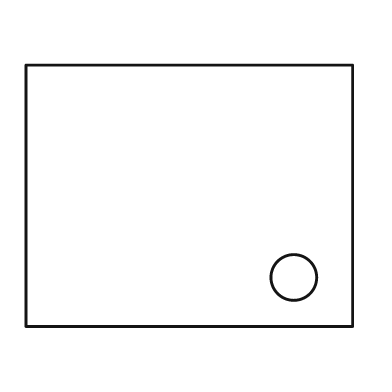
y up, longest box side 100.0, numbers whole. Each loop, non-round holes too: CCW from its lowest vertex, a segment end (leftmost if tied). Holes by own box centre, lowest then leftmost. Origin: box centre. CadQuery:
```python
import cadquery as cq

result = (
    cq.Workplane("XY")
    .moveTo(-50.0, -40.0)
    .lineTo(50.0, -40.0)
    .lineTo(50.0, 40.0)
    .lineTo(-50.0, 40.0)
    .close()
    .moveTo(32.0, -25.0)
    .circle(7.0)
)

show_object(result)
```